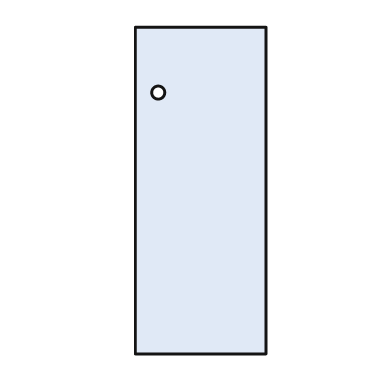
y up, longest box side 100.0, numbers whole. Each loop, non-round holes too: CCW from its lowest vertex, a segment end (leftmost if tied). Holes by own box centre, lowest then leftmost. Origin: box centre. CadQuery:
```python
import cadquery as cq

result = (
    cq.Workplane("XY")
    .moveTo(-20.0, -50.0)
    .lineTo(20.0, -50.0)
    .lineTo(20.0, 50.0)
    .lineTo(-20.0, 50.0)
    .close()
    .moveTo(-13.0, 30.0)
    .circle(2.0)
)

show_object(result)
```